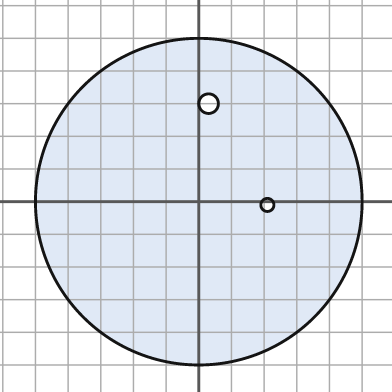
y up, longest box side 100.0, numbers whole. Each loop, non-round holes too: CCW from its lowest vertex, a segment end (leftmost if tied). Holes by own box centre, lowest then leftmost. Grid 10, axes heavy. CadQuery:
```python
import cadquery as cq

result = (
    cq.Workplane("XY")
    .moveTo(0.0, 0.0)
    .circle(50.0)
    .moveTo(21.0, -1.0)
    .circle(2.0)
    .moveTo(3.0, 30.0)
    .circle(3.0)
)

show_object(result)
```